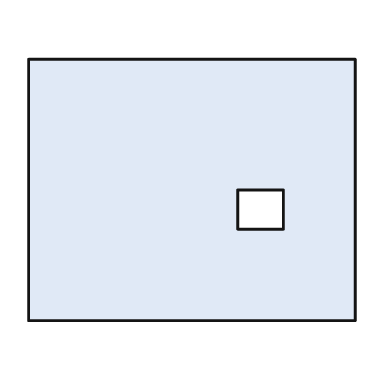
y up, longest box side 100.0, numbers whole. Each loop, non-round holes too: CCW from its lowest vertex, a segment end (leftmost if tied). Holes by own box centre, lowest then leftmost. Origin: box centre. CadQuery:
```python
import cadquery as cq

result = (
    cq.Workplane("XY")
    .moveTo(-50.0, -40.0)
    .lineTo(50.0, -40.0)
    .lineTo(50.0, 40.0)
    .lineTo(-50.0, 40.0)
    .close()
    .moveTo(14.0, -12.0)
    .lineTo(28.0, -12.0)
    .lineTo(28.0, 0.0)
    .lineTo(14.0, 0.0)
    .close()
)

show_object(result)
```